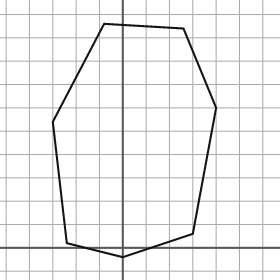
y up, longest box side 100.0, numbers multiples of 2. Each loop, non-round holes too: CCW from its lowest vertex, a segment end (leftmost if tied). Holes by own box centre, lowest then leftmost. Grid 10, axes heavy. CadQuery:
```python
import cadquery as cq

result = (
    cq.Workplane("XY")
    .moveTo(0.0, -4.0)
    .lineTo(30.0, 6.0)
    .lineTo(40.0, 60.0)
    .lineTo(26.0, 94.0)
    .lineTo(-8.0, 96.0)
    .lineTo(-30.0, 54.0)
    .lineTo(-24.0, 2.0)
    .close()
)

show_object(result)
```